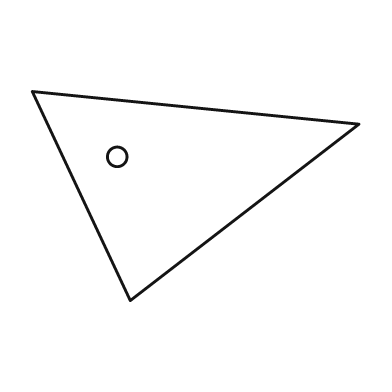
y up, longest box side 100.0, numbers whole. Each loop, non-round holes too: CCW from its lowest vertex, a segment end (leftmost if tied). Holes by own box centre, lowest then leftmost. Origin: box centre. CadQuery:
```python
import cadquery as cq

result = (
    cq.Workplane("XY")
    .moveTo(-20.0, -32.0)
    .lineTo(50.0, 22.0)
    .lineTo(-50.0, 32.0)
    .close()
    .moveTo(-24.0, 12.0)
    .circle(3.0)
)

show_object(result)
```